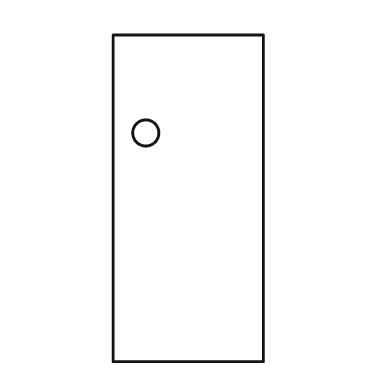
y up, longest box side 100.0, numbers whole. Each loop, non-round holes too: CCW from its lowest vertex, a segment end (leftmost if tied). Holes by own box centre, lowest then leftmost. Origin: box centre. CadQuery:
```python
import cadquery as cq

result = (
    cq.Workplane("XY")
    .moveTo(-23.0, -50.0)
    .lineTo(23.0, -50.0)
    .lineTo(23.0, 50.0)
    .lineTo(-23.0, 50.0)
    .close()
    .moveTo(-13.0, 20.0)
    .circle(4.0)
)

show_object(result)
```